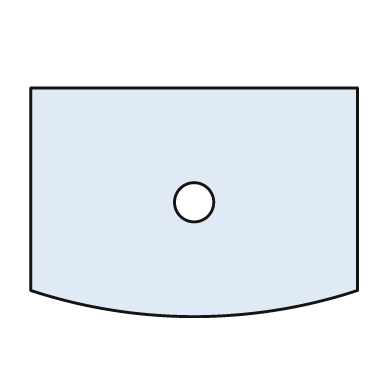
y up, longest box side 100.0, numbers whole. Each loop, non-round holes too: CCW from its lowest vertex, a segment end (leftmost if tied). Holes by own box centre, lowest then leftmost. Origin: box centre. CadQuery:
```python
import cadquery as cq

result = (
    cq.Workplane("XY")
    .moveTo(-50.0, -27.0)
    .threePointArc((0.0, -35.0), (50.0, -27.0))
    .lineTo(50.0, 35.0)
    .lineTo(-50.0, 35.0)
    .close()
    .moveTo(0.0, 0.0)
    .circle(6.0)
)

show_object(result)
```